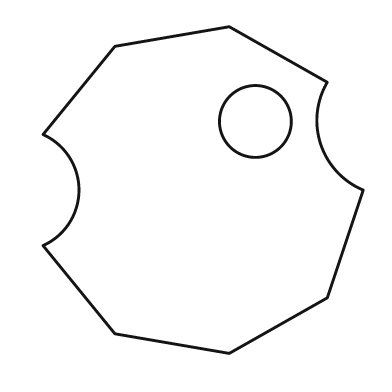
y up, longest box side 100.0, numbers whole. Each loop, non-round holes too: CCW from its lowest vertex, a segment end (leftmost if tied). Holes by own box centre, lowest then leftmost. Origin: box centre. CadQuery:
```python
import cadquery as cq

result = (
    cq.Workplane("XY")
    .moveTo(8.0, -50.0)
    .lineTo(38.0, -33.0)
    .lineTo(49.0, 0.0)
    .threePointArc((36.0, 14.0), (38.0, 33.0))
    .lineTo(8.0, 50.0)
    .lineTo(-27.0, 44.0)
    .lineTo(-49.0, 17.0)
    .threePointArc((-38.0, 0.0), (-49.0, -17.0))
    .lineTo(-27.0, -44.0)
    .close()
    .moveTo(16.0, 21.0)
    .circle(11.0)
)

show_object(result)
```